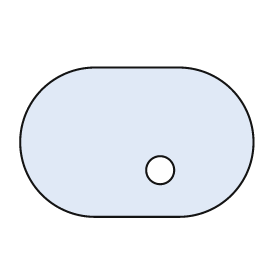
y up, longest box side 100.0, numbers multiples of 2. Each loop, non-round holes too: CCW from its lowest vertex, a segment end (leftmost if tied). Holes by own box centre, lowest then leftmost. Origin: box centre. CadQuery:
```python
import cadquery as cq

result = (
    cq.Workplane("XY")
    .moveTo(-18.0, -32.0)
    .lineTo(18.0, -32.0)
    .threePointArc((50.0, 0.0), (18.0, 32.0))
    .lineTo(-18.0, 32.0)
    .threePointArc((-50.0, 0.0), (-18.0, -32.0))
    .close()
    .moveTo(10.0, -12.0)
    .circle(6.0)
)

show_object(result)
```